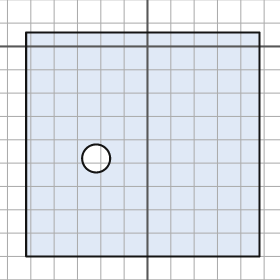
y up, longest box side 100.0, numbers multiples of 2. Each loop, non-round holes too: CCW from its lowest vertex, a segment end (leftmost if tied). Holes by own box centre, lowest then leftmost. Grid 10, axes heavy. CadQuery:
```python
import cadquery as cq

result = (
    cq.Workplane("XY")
    .moveTo(-52.0, -90.0)
    .lineTo(48.0, -90.0)
    .lineTo(48.0, 6.0)
    .lineTo(-52.0, 6.0)
    .close()
    .moveTo(-22.0, -48.0)
    .circle(6.0)
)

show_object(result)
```